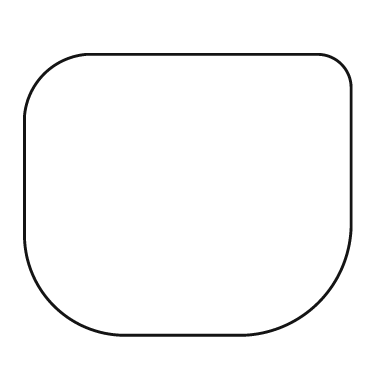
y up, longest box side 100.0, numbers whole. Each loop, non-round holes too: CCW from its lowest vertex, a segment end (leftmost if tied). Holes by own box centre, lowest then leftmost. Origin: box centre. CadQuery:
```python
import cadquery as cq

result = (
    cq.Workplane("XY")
    .moveTo(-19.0, -43.0)
    .lineTo(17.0, -43.0)
    .threePointArc((40.0, -33.0), (50.0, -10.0))
    .lineTo(50.0, 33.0)
    .threePointArc((47.0, 40.0), (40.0, 43.0))
    .lineTo(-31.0, 43.0)
    .threePointArc((-44.0, 37.0), (-50.0, 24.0))
    .lineTo(-50.0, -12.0)
    .threePointArc((-41.0, -34.0), (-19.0, -43.0))
    .close()
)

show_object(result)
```